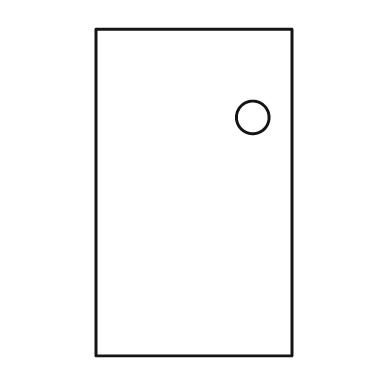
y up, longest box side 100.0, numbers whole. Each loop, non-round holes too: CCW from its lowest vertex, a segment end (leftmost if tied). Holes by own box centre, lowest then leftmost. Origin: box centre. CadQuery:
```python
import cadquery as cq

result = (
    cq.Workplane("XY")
    .moveTo(-30.0, -50.0)
    .lineTo(30.0, -50.0)
    .lineTo(30.0, 50.0)
    .lineTo(-30.0, 50.0)
    .close()
    .moveTo(18.0, 23.0)
    .circle(5.0)
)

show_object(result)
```